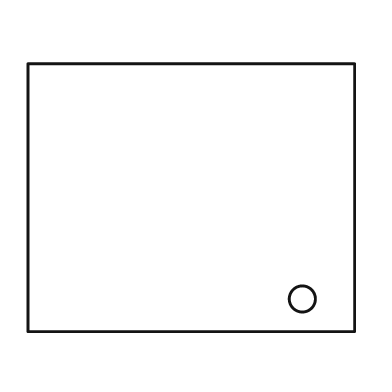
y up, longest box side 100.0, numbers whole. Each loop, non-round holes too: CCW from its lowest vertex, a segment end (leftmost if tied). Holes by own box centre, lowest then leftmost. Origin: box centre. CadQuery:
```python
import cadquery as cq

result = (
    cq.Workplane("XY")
    .moveTo(-50.0, -41.0)
    .lineTo(50.0, -41.0)
    .lineTo(50.0, 41.0)
    .lineTo(-50.0, 41.0)
    .close()
    .moveTo(34.0, -31.0)
    .circle(4.0)
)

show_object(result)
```